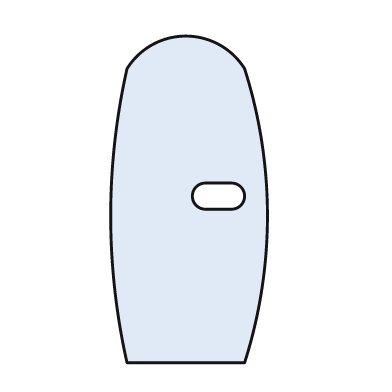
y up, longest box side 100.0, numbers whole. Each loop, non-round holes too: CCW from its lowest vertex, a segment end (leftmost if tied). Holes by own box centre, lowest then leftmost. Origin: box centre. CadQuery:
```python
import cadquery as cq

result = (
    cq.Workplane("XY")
    .moveTo(-19.0, -50.0)
    .lineTo(17.0, -50.0)
    .threePointArc((24.0, -5.0), (17.0, 40.0))
    .threePointArc((-1.0, 50.0), (-19.0, 40.0))
    .threePointArc((-24.0, -5.0), (-19.0, -50.0))
    .close()
    .moveTo(5.0, -3.0)
    .lineTo(13.0, -3.0)
    .threePointArc((17.0, 1.0), (13.0, 5.0))
    .lineTo(5.0, 5.0)
    .threePointArc((1.0, 1.0), (5.0, -3.0))
    .close()
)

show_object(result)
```